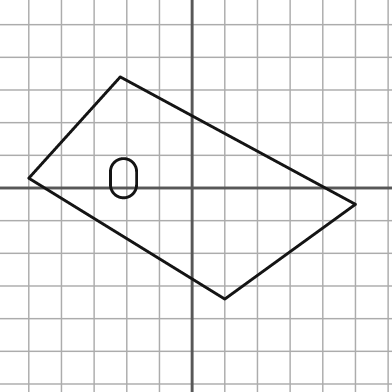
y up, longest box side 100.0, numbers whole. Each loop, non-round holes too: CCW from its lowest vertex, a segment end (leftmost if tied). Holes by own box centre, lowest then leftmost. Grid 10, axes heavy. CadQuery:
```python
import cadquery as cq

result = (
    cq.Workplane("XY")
    .moveTo(10.0, -34.0)
    .lineTo(50.0, -5.0)
    .lineTo(-22.0, 34.0)
    .lineTo(-50.0, 3.0)
    .close()
    .moveTo(-25.0, 1.0)
    .threePointArc((-21.0, -3.0), (-17.0, 1.0))
    .lineTo(-17.0, 5.0)
    .threePointArc((-21.0, 9.0), (-25.0, 5.0))
    .close()
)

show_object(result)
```